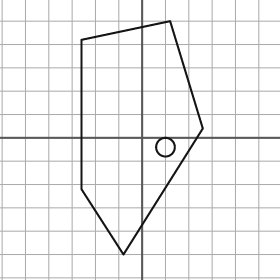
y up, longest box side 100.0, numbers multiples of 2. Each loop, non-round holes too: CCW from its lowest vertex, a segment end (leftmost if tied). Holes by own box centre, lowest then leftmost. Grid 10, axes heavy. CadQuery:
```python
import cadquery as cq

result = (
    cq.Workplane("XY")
    .moveTo(-8.0, -50.0)
    .lineTo(26.0, 4.0)
    .lineTo(12.0, 50.0)
    .lineTo(-26.0, 42.0)
    .lineTo(-26.0, -22.0)
    .close()
    .moveTo(10.0, -4.0)
    .circle(4.0)
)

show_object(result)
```